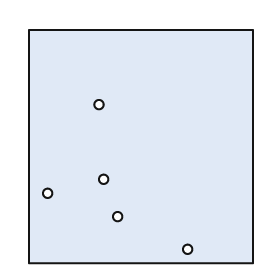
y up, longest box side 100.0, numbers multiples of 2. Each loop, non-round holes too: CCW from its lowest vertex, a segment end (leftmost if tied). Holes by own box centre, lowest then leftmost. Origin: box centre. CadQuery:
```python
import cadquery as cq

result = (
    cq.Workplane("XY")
    .moveTo(-48.0, -50.0)
    .lineTo(48.0, -50.0)
    .lineTo(48.0, 50.0)
    .lineTo(-48.0, 50.0)
    .close()
    .moveTo(20.0, -44.0)
    .circle(2.0)
    .moveTo(-10.0, -30.0)
    .circle(2.0)
    .moveTo(-40.0, -20.0)
    .circle(2.0)
    .moveTo(-16.0, -14.0)
    .circle(2.0)
    .moveTo(-18.0, 18.0)
    .circle(2.0)
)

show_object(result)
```